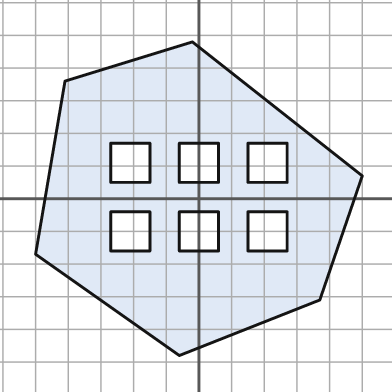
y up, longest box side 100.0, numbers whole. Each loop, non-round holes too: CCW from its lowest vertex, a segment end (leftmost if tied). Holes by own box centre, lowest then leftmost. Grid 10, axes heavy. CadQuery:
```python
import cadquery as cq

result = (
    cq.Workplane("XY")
    .moveTo(-6.0, -48.0)
    .lineTo(37.0, -31.0)
    .lineTo(50.0, 7.0)
    .lineTo(-2.0, 48.0)
    .lineTo(-41.0, 36.0)
    .lineTo(-50.0, -17.0)
    .close()
    .moveTo(-27.0, -16.0)
    .lineTo(-15.0, -16.0)
    .lineTo(-15.0, -4.0)
    .lineTo(-27.0, -4.0)
    .close()
    .moveTo(-6.0, -16.0)
    .lineTo(6.0, -16.0)
    .lineTo(6.0, -4.0)
    .lineTo(-6.0, -4.0)
    .close()
    .moveTo(15.0, -16.0)
    .lineTo(27.0, -16.0)
    .lineTo(27.0, -4.0)
    .lineTo(15.0, -4.0)
    .close()
    .moveTo(-27.0, 5.0)
    .lineTo(-15.0, 5.0)
    .lineTo(-15.0, 17.0)
    .lineTo(-27.0, 17.0)
    .close()
    .moveTo(-6.0, 5.0)
    .lineTo(6.0, 5.0)
    .lineTo(6.0, 17.0)
    .lineTo(-6.0, 17.0)
    .close()
    .moveTo(15.0, 5.0)
    .lineTo(27.0, 5.0)
    .lineTo(27.0, 17.0)
    .lineTo(15.0, 17.0)
    .close()
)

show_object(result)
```